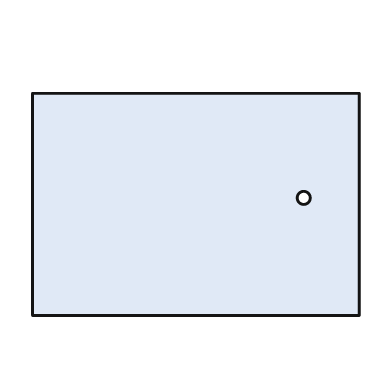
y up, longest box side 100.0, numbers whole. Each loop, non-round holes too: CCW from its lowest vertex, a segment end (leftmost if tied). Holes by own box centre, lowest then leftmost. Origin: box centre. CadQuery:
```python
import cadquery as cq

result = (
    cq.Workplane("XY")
    .moveTo(-50.0, -34.0)
    .lineTo(50.0, -34.0)
    .lineTo(50.0, 34.0)
    .lineTo(-50.0, 34.0)
    .close()
    .moveTo(33.0, 2.0)
    .circle(2.0)
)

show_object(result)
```